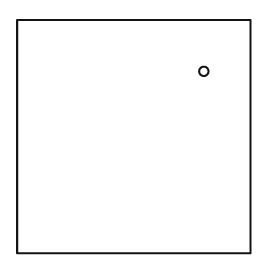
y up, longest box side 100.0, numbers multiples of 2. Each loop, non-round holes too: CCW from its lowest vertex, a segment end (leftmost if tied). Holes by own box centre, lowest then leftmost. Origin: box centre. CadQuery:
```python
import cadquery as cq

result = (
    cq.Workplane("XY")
    .moveTo(-50.0, -50.0)
    .lineTo(50.0, -50.0)
    .lineTo(50.0, 50.0)
    .lineTo(-50.0, 50.0)
    .close()
    .moveTo(30.0, 28.0)
    .circle(2.0)
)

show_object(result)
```